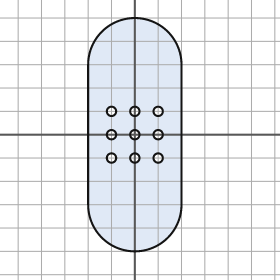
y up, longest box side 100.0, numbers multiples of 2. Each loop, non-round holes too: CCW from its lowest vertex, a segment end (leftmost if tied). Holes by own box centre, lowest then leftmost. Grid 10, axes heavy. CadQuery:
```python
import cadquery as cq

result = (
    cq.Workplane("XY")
    .moveTo(-20.0, -30.0)
    .threePointArc((0.0, -50.0), (20.0, -30.0))
    .lineTo(20.0, 30.0)
    .threePointArc((0.0, 50.0), (-20.0, 30.0))
    .close()
    .moveTo(-10.0, -10.0)
    .circle(2.0)
    .moveTo(0.0, -10.0)
    .circle(2.0)
    .moveTo(10.0, -10.0)
    .circle(2.0)
    .moveTo(-10.0, 0.0)
    .circle(2.0)
    .moveTo(0.0, 0.0)
    .circle(2.0)
    .moveTo(10.0, 0.0)
    .circle(2.0)
    .moveTo(-10.0, 10.0)
    .circle(2.0)
    .moveTo(0.0, 10.0)
    .circle(2.0)
    .moveTo(10.0, 10.0)
    .circle(2.0)
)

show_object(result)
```